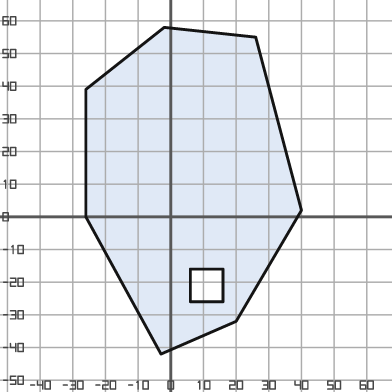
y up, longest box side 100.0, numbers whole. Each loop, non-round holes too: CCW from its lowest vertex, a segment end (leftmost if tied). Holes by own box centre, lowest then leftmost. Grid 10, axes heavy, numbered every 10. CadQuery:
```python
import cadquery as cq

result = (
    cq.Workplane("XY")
    .moveTo(-3.0, -42.0)
    .lineTo(20.0, -32.0)
    .lineTo(40.0, 2.0)
    .lineTo(26.0, 55.0)
    .lineTo(-2.0, 58.0)
    .lineTo(-26.0, 39.0)
    .lineTo(-26.0, 0.0)
    .close()
    .moveTo(6.0, -26.0)
    .lineTo(16.0, -26.0)
    .lineTo(16.0, -16.0)
    .lineTo(6.0, -16.0)
    .close()
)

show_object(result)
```